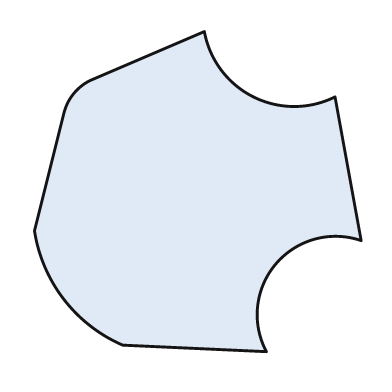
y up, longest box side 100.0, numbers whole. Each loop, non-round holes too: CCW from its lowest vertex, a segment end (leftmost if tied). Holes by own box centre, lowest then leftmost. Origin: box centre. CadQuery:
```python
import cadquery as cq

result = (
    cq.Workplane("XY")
    .moveTo(21.0, -49.0)
    .threePointArc((24.0, -22.0), (50.0, -15.0))
    .lineTo(42.0, 29.0)
    .threePointArc((17.0, 29.0), (2.0, 49.0))
    .lineTo(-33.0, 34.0)
    .threePointArc((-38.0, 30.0), (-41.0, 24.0))
    .lineTo(-50.0, -12.0)
    .threePointArc((-41.0, -33.0), (-23.0, -47.0))
    .close()
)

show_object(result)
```